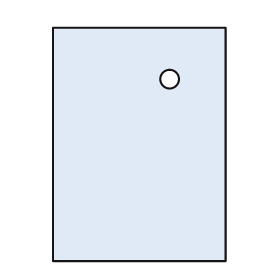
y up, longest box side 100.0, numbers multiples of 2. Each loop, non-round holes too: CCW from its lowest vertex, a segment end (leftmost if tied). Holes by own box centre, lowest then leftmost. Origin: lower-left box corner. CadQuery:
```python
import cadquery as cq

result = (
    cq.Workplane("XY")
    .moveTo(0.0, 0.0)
    .lineTo(74.0, 0.0)
    .lineTo(74.0, 100.0)
    .lineTo(0.0, 100.0)
    .close()
    .moveTo(50.0, 78.0)
    .circle(4.0)
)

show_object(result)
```